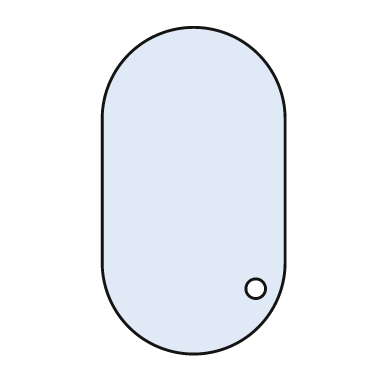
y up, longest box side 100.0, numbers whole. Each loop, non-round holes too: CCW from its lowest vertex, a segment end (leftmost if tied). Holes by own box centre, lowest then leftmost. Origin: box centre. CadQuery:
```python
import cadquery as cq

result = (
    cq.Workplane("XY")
    .moveTo(-28.0, -22.0)
    .threePointArc((0.0, -50.0), (28.0, -22.0))
    .lineTo(28.0, 22.0)
    .threePointArc((0.0, 50.0), (-28.0, 22.0))
    .close()
    .moveTo(19.0, -30.0)
    .circle(3.0)
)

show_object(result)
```